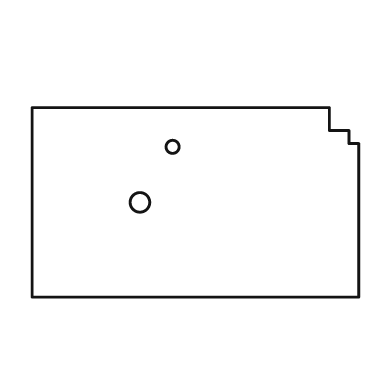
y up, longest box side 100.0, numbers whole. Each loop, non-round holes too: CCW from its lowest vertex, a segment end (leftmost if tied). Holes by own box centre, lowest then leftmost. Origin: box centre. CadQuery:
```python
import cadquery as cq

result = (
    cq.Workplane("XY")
    .moveTo(-50.0, -29.0)
    .lineTo(50.0, -29.0)
    .lineTo(50.0, 18.0)
    .lineTo(47.0, 18.0)
    .lineTo(47.0, 22.0)
    .lineTo(41.0, 22.0)
    .lineTo(41.0, 29.0)
    .lineTo(-50.0, 29.0)
    .close()
    .moveTo(-17.0, 0.0)
    .circle(3.0)
    .moveTo(-7.0, 17.0)
    .circle(2.0)
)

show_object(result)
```